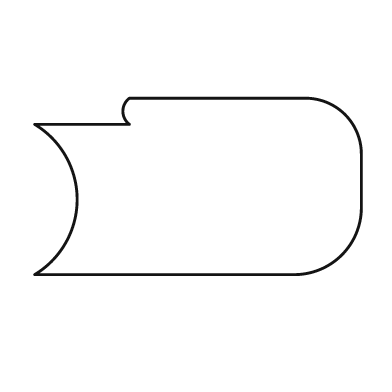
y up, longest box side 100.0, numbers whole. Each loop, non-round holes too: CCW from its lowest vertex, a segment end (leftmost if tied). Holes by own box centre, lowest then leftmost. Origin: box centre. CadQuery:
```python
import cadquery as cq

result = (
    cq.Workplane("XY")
    .moveTo(-50.0, -27.0)
    .lineTo(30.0, -27.0)
    .threePointArc((44.0, -21.0), (50.0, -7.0))
    .lineTo(50.0, 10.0)
    .threePointArc((45.0, 22.0), (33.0, 27.0))
    .lineTo(-21.0, 27.0)
    .threePointArc((-23.0, 23.0), (-21.0, 19.0))
    .lineTo(-50.0, 19.0)
    .threePointArc((-37.0, -4.0), (-50.0, -27.0))
    .close()
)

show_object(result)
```